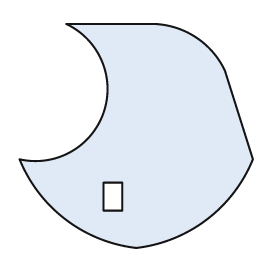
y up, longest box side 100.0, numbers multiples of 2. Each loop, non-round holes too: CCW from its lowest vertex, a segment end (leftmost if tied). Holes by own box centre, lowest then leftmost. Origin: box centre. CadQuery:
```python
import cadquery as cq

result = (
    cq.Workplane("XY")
    .moveTo(0.0, -48.0)
    .threePointArc((30.0, -36.0), (50.0, -10.0))
    .lineTo(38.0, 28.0)
    .threePointArc((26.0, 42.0), (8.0, 48.0))
    .lineTo(-30.0, 48.0)
    .threePointArc((-14.0, 10.0), (-50.0, -10.0))
    .threePointArc((-30.0, -36.0), (0.0, -48.0))
    .close()
    .moveTo(-14.0, -32.0)
    .lineTo(-6.0, -32.0)
    .lineTo(-6.0, -20.0)
    .lineTo(-14.0, -20.0)
    .close()
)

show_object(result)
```